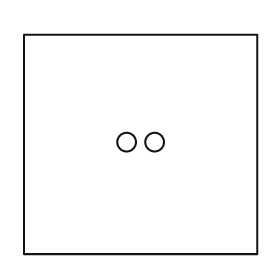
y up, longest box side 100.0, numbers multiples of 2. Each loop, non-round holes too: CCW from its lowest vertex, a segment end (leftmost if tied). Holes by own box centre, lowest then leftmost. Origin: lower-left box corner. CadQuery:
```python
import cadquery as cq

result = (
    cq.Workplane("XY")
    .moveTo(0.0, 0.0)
    .lineTo(100.0, 0.0)
    .lineTo(100.0, 94.0)
    .lineTo(0.0, 94.0)
    .close()
    .moveTo(44.0, 48.0)
    .circle(4.0)
    .moveTo(56.0, 48.0)
    .circle(4.0)
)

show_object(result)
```